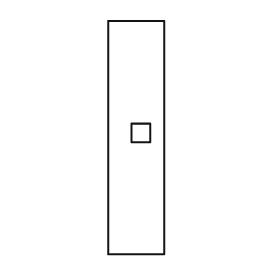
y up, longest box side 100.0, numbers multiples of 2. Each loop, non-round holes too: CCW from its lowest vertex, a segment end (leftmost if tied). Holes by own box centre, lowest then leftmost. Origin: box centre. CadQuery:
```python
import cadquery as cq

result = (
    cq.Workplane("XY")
    .moveTo(-12.0, -50.0)
    .lineTo(12.0, -50.0)
    .lineTo(12.0, 50.0)
    .lineTo(-12.0, 50.0)
    .close()
    .moveTo(-2.0, -2.0)
    .lineTo(6.0, -2.0)
    .lineTo(6.0, 6.0)
    .lineTo(-2.0, 6.0)
    .close()
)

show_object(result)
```